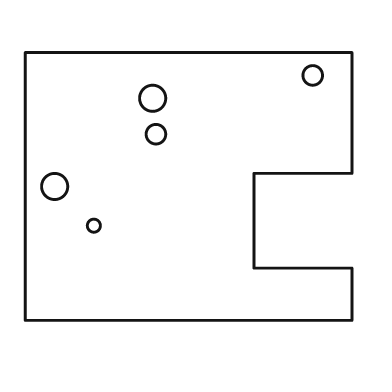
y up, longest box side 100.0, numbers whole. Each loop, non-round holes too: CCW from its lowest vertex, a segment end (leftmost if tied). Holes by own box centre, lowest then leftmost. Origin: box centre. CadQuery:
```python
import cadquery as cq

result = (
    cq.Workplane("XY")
    .moveTo(-50.0, -41.0)
    .lineTo(50.0, -41.0)
    .lineTo(50.0, -25.0)
    .lineTo(20.0, -25.0)
    .lineTo(20.0, 4.0)
    .lineTo(50.0, 4.0)
    .lineTo(50.0, 41.0)
    .lineTo(-50.0, 41.0)
    .close()
    .moveTo(-29.0, -12.0)
    .circle(2.0)
    .moveTo(-41.0, 0.0)
    .circle(4.0)
    .moveTo(-10.0, 16.0)
    .circle(3.0)
    .moveTo(-11.0, 27.0)
    .circle(4.0)
    .moveTo(38.0, 34.0)
    .circle(3.0)
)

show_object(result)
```